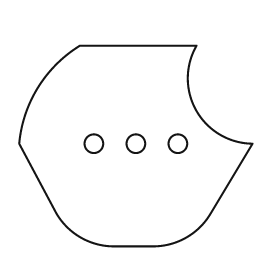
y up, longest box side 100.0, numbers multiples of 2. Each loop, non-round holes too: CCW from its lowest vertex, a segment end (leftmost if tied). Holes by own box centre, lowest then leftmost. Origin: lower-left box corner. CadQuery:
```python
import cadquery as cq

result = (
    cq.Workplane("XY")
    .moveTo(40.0, 0.0)
    .lineTo(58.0, 0.0)
    .threePointArc((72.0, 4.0), (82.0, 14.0))
    .lineTo(100.0, 44.0)
    .threePointArc((76.0, 58.0), (76.0, 86.0))
    .lineTo(26.0, 86.0)
    .threePointArc((8.0, 68.0), (0.0, 44.0))
    .lineTo(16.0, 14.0)
    .threePointArc((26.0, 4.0), (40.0, 0.0))
    .close()
    .moveTo(32.0, 44.0)
    .circle(4.0)
    .moveTo(50.0, 44.0)
    .circle(4.0)
    .moveTo(68.0, 44.0)
    .circle(4.0)
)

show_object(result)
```